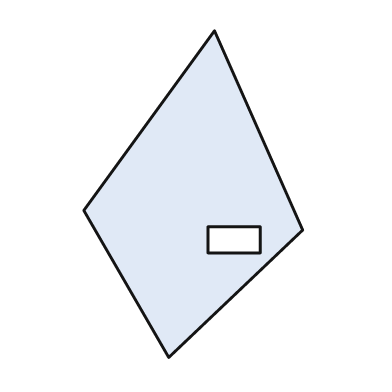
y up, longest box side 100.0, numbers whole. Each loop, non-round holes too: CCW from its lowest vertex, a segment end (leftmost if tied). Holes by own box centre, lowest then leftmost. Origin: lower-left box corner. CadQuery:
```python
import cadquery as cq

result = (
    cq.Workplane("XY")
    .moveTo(26.0, 0.0)
    .lineTo(67.0, 39.0)
    .lineTo(40.0, 100.0)
    .lineTo(0.0, 45.0)
    .close()
    .moveTo(38.0, 32.0)
    .lineTo(54.0, 32.0)
    .lineTo(54.0, 40.0)
    .lineTo(38.0, 40.0)
    .close()
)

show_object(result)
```